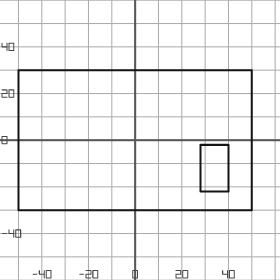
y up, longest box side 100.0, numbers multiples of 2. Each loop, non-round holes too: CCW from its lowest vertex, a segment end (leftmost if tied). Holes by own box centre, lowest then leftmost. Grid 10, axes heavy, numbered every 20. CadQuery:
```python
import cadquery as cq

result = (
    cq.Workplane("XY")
    .moveTo(-50.0, -30.0)
    .lineTo(50.0, -30.0)
    .lineTo(50.0, 30.0)
    .lineTo(-50.0, 30.0)
    .close()
    .moveTo(28.0, -22.0)
    .lineTo(40.0, -22.0)
    .lineTo(40.0, -2.0)
    .lineTo(28.0, -2.0)
    .close()
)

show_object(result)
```